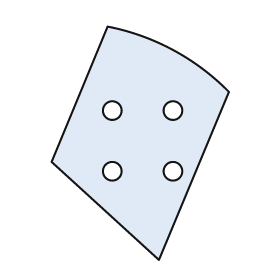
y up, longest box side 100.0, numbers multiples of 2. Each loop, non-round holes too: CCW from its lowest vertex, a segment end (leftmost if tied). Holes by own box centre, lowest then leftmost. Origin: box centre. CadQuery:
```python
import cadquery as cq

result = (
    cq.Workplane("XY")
    .moveTo(8.0, -50.0)
    .lineTo(38.0, 22.0)
    .threePointArc((14.0, 40.0), (-14.0, 50.0))
    .lineTo(-38.0, -8.0)
    .close()
    .moveTo(-12.0, -12.0)
    .circle(4.0)
    .moveTo(14.0, -12.0)
    .circle(4.0)
    .moveTo(-12.0, 14.0)
    .circle(4.0)
    .moveTo(14.0, 14.0)
    .circle(4.0)
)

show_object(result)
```